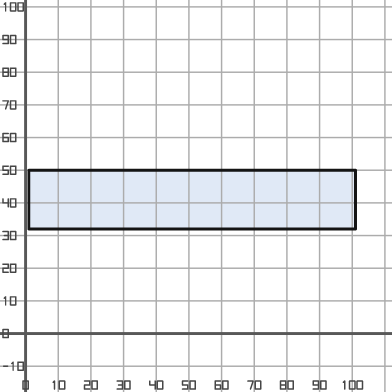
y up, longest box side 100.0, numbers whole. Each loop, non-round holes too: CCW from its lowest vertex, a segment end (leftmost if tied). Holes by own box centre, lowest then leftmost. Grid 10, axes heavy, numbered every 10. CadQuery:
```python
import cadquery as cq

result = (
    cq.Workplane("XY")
    .moveTo(1.0, 32.0)
    .lineTo(101.0, 32.0)
    .lineTo(101.0, 50.0)
    .lineTo(1.0, 50.0)
    .close()
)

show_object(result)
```